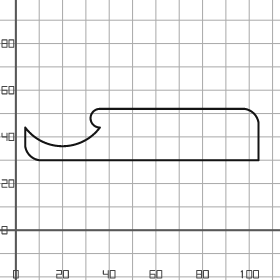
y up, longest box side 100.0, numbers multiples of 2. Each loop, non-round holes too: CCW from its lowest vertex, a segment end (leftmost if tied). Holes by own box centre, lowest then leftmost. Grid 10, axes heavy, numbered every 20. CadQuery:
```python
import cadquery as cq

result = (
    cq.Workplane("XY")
    .moveTo(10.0, 30.0)
    .lineTo(104.0, 30.0)
    .lineTo(104.0, 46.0)
    .threePointArc((102.0, 50.0), (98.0, 52.0))
    .lineTo(36.0, 52.0)
    .threePointArc((32.0, 48.0), (36.0, 44.0))
    .threePointArc((20.0, 36.0), (4.0, 44.0))
    .lineTo(4.0, 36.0)
    .threePointArc((6.0, 32.0), (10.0, 30.0))
    .close()
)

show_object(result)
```